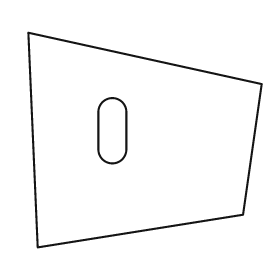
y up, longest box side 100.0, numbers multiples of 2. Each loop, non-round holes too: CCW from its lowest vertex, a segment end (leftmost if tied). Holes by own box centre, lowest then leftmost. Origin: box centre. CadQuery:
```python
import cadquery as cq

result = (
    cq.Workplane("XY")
    .moveTo(-46.0, -46.0)
    .lineTo(42.0, -32.0)
    .lineTo(50.0, 24.0)
    .lineTo(-50.0, 46.0)
    .close()
    .moveTo(-20.0, -4.0)
    .threePointArc((-14.0, -10.0), (-8.0, -4.0))
    .lineTo(-8.0, 12.0)
    .threePointArc((-14.0, 18.0), (-20.0, 12.0))
    .close()
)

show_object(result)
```